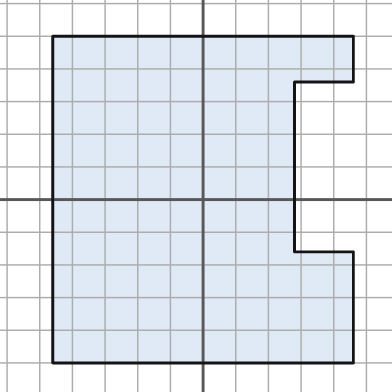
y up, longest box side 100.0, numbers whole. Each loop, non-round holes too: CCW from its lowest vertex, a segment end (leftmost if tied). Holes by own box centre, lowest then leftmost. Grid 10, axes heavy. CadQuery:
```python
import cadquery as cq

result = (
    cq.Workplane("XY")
    .moveTo(-46.0, -50.0)
    .lineTo(46.0, -50.0)
    .lineTo(46.0, -16.0)
    .lineTo(28.0, -16.0)
    .lineTo(28.0, 36.0)
    .lineTo(46.0, 36.0)
    .lineTo(46.0, 50.0)
    .lineTo(-46.0, 50.0)
    .close()
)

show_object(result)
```